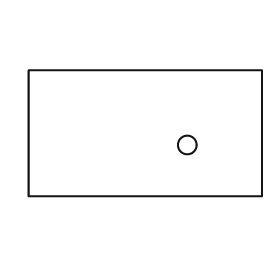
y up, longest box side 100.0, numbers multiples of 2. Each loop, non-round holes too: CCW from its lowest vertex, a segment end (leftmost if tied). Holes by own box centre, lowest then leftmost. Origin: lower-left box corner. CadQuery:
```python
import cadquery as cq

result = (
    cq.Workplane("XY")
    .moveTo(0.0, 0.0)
    .lineTo(100.0, 0.0)
    .lineTo(100.0, 54.0)
    .lineTo(0.0, 54.0)
    .close()
    .moveTo(68.0, 22.0)
    .circle(4.0)
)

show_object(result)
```